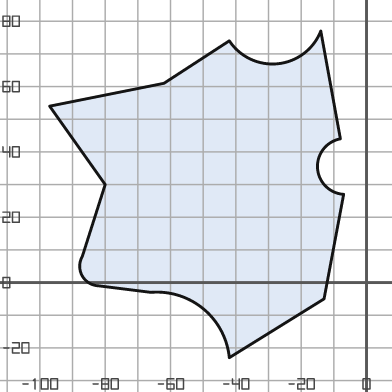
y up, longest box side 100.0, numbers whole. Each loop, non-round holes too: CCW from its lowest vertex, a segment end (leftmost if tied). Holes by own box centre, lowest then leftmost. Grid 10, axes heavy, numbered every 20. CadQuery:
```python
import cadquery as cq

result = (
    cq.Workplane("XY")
    .moveTo(-42.0, -23.0)
    .lineTo(-13.0, -5.0)
    .lineTo(-7.0, 27.0)
    .threePointArc((-15.0, 35.0), (-8.0, 44.0))
    .lineTo(-14.0, 77.0)
    .threePointArc((-27.0, 67.0), (-42.0, 74.0))
    .lineTo(-62.0, 61.0)
    .lineTo(-97.0, 54.0)
    .lineTo(-80.0, 30.0)
    .lineTo(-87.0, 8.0)
    .threePointArc((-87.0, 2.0), (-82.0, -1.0))
    .lineTo(-66.0, -3.0)
    .threePointArc((-50.0, -8.0), (-42.0, -23.0))
    .close()
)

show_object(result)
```